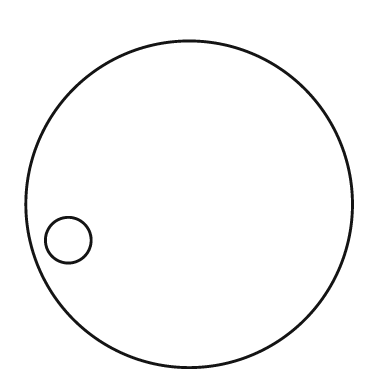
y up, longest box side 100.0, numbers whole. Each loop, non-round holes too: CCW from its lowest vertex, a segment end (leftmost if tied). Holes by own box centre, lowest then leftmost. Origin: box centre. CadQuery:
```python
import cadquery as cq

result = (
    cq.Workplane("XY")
    .moveTo(0.0, 0.0)
    .circle(50.0)
    .moveTo(-37.0, -11.0)
    .circle(7.0)
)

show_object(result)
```